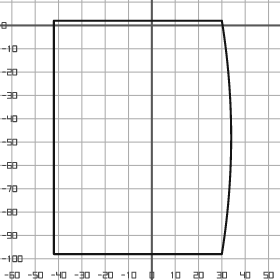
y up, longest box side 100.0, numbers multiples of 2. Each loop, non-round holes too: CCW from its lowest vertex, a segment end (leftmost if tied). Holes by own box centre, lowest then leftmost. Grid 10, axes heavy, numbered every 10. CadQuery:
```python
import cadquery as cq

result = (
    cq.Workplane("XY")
    .moveTo(-42.0, -98.0)
    .lineTo(30.0, -98.0)
    .threePointArc((34.0, -48.0), (30.0, 2.0))
    .lineTo(-42.0, 2.0)
    .close()
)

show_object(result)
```